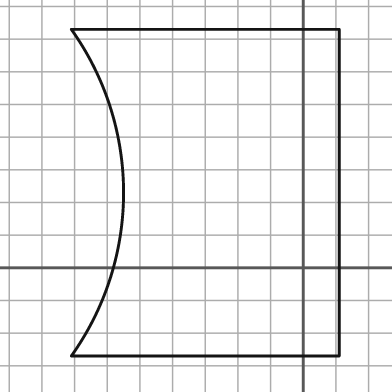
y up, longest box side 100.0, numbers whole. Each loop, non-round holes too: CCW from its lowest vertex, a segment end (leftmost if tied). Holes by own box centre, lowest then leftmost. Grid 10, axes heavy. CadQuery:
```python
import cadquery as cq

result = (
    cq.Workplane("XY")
    .moveTo(-71.0, -27.0)
    .lineTo(11.0, -27.0)
    .lineTo(11.0, 73.0)
    .lineTo(-71.0, 73.0)
    .threePointArc((-55.0, 23.0), (-71.0, -27.0))
    .close()
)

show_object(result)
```